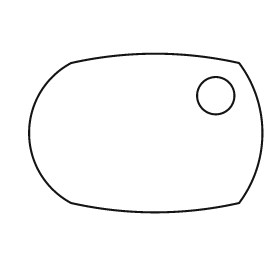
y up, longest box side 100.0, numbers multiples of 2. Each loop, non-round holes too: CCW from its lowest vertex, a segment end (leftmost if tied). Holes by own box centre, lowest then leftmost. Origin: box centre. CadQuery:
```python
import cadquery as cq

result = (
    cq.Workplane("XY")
    .moveTo(-32.0, -30.0)
    .threePointArc((4.0, -34.0), (40.0, -30.0))
    .threePointArc((50.0, 0.0), (40.0, 30.0))
    .threePointArc((4.0, 34.0), (-32.0, 30.0))
    .threePointArc((-50.0, 0.0), (-32.0, -30.0))
    .close()
    .moveTo(30.0, 16.0)
    .circle(8.0)
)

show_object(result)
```